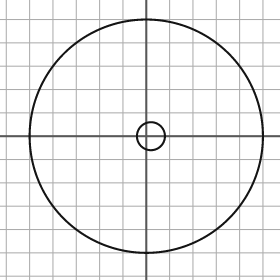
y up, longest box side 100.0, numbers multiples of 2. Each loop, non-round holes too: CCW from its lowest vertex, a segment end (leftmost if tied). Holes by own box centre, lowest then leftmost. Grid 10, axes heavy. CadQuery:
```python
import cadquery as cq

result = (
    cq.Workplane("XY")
    .moveTo(0.0, 0.0)
    .circle(50.0)
    .moveTo(2.0, 0.0)
    .circle(6.0)
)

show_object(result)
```